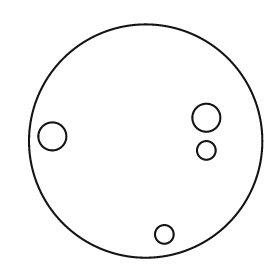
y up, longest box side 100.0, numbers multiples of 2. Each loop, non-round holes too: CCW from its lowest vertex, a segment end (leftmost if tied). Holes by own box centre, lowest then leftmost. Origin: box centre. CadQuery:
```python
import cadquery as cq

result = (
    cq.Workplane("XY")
    .moveTo(0.0, 0.0)
    .circle(50.0)
    .moveTo(8.0, -40.0)
    .circle(4.0)
    .moveTo(26.0, -4.0)
    .circle(4.0)
    .moveTo(-40.0, 2.0)
    .circle(6.0)
    .moveTo(26.0, 10.0)
    .circle(6.0)
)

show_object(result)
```